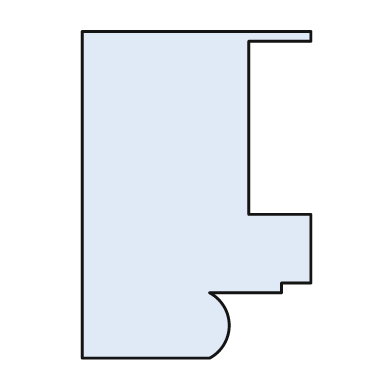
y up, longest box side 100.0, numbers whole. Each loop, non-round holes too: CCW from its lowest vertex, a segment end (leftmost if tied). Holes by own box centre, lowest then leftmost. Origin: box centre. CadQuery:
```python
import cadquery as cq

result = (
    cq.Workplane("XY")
    .moveTo(-35.0, -50.0)
    .lineTo(4.0, -50.0)
    .threePointArc((10.0, -40.0), (4.0, -30.0))
    .lineTo(26.0, -30.0)
    .lineTo(26.0, -27.0)
    .lineTo(35.0, -27.0)
    .lineTo(35.0, -6.0)
    .lineTo(16.0, -6.0)
    .lineTo(16.0, 47.0)
    .lineTo(35.0, 47.0)
    .lineTo(35.0, 50.0)
    .lineTo(-35.0, 50.0)
    .close()
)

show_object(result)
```